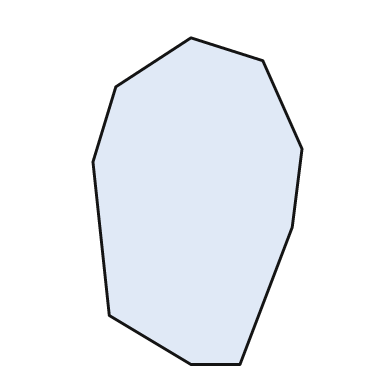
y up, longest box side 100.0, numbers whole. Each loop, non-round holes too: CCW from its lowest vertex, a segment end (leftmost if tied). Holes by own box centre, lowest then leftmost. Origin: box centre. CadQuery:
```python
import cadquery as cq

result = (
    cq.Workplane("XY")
    .moveTo(-2.0, -50.0)
    .lineTo(13.0, -50.0)
    .lineTo(29.0, -8.0)
    .lineTo(32.0, 16.0)
    .lineTo(20.0, 43.0)
    .lineTo(-2.0, 50.0)
    .lineTo(-25.0, 35.0)
    .lineTo(-32.0, 12.0)
    .lineTo(-27.0, -35.0)
    .close()
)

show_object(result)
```